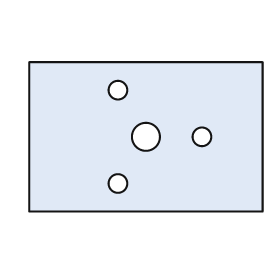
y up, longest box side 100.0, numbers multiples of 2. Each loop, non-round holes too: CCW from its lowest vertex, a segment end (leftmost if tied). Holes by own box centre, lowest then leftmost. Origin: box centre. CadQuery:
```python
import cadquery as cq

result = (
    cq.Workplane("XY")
    .moveTo(-50.0, -32.0)
    .lineTo(50.0, -32.0)
    .lineTo(50.0, 32.0)
    .lineTo(-50.0, 32.0)
    .close()
    .moveTo(-12.0, -20.0)
    .circle(4.0)
    .moveTo(0.0, 0.0)
    .circle(6.0)
    .moveTo(24.0, 0.0)
    .circle(4.0)
    .moveTo(-12.0, 20.0)
    .circle(4.0)
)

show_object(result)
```